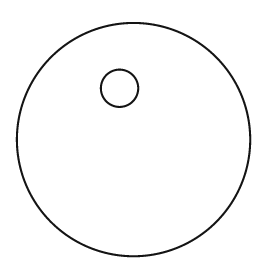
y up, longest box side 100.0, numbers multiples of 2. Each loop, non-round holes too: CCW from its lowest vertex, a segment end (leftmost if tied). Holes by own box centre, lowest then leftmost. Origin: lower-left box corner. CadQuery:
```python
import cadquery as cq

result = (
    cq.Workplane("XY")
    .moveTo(50.0, 50.0)
    .circle(50.0)
    .moveTo(44.0, 72.0)
    .circle(8.0)
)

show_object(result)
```